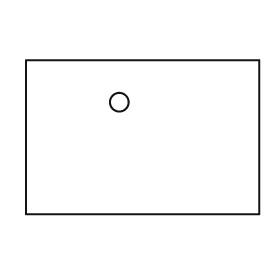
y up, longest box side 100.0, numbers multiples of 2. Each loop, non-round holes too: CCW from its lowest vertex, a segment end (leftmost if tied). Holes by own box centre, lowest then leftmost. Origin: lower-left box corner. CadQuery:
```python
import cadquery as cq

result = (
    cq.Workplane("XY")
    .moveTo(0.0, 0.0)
    .lineTo(100.0, 0.0)
    .lineTo(100.0, 66.0)
    .lineTo(0.0, 66.0)
    .close()
    .moveTo(40.0, 48.0)
    .circle(4.0)
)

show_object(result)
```